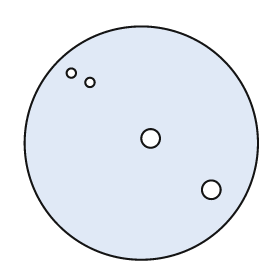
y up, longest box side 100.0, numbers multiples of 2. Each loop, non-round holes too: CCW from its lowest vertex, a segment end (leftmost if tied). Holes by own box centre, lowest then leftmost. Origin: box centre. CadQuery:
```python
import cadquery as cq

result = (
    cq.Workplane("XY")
    .moveTo(0.0, 0.0)
    .circle(50.0)
    .moveTo(30.0, -20.0)
    .circle(4.0)
    .moveTo(4.0, 2.0)
    .circle(4.0)
    .moveTo(-22.0, 26.0)
    .circle(2.0)
    .moveTo(-30.0, 30.0)
    .circle(2.0)
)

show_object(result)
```